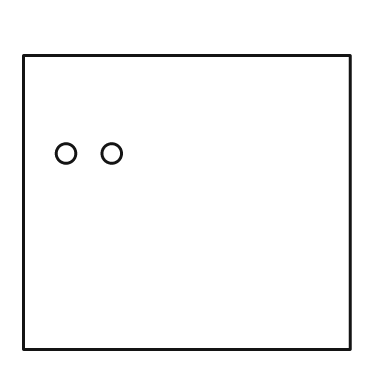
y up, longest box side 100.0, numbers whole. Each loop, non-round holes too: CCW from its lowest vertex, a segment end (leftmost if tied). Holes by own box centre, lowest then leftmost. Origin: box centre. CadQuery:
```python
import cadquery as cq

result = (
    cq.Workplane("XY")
    .moveTo(-50.0, -45.0)
    .lineTo(50.0, -45.0)
    .lineTo(50.0, 45.0)
    .lineTo(-50.0, 45.0)
    .close()
    .moveTo(-37.0, 15.0)
    .circle(3.0)
    .moveTo(-23.0, 15.0)
    .circle(3.0)
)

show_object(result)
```